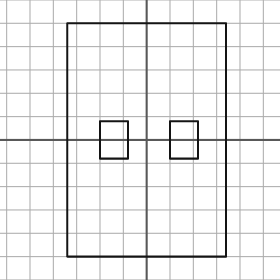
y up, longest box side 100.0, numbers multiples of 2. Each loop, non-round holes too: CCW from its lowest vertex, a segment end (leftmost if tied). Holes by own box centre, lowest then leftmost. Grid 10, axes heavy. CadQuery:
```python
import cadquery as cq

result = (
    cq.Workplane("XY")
    .moveTo(-34.0, -50.0)
    .lineTo(34.0, -50.0)
    .lineTo(34.0, 50.0)
    .lineTo(-34.0, 50.0)
    .close()
    .moveTo(-20.0, -8.0)
    .lineTo(-8.0, -8.0)
    .lineTo(-8.0, 8.0)
    .lineTo(-20.0, 8.0)
    .close()
    .moveTo(10.0, -8.0)
    .lineTo(22.0, -8.0)
    .lineTo(22.0, 8.0)
    .lineTo(10.0, 8.0)
    .close()
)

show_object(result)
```